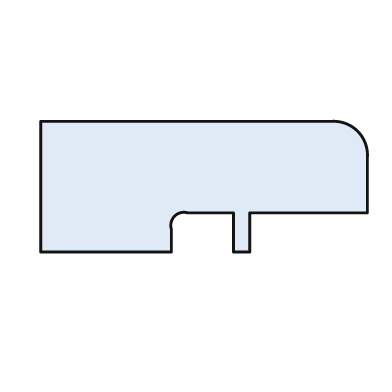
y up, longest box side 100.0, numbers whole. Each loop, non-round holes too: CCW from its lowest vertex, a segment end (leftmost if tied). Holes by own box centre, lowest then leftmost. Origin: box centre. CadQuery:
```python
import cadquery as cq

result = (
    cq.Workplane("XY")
    .moveTo(-50.0, -20.0)
    .lineTo(-10.0, -20.0)
    .lineTo(-10.0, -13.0)
    .threePointArc((-9.0, -9.0), (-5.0, -8.0))
    .lineTo(9.0, -8.0)
    .lineTo(9.0, -20.0)
    .lineTo(14.0, -20.0)
    .lineTo(14.0, -8.0)
    .lineTo(50.0, -8.0)
    .lineTo(50.0, 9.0)
    .threePointArc((47.0, 17.0), (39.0, 20.0))
    .lineTo(-50.0, 20.0)
    .close()
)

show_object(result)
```